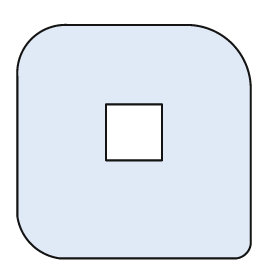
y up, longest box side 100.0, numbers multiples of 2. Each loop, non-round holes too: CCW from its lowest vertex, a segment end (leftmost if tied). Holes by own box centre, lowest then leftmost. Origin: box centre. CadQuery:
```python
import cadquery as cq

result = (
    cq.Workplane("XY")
    .moveTo(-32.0, -50.0)
    .lineTo(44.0, -50.0)
    .threePointArc((48.0, -48.0), (50.0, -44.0))
    .lineTo(50.0, 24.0)
    .threePointArc((42.0, 42.0), (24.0, 50.0))
    .lineTo(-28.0, 50.0)
    .threePointArc((-44.0, 44.0), (-50.0, 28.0))
    .lineTo(-50.0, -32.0)
    .threePointArc((-44.0, -44.0), (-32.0, -50.0))
    .close()
    .moveTo(-12.0, -8.0)
    .lineTo(12.0, -8.0)
    .lineTo(12.0, 16.0)
    .lineTo(-12.0, 16.0)
    .close()
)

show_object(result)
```